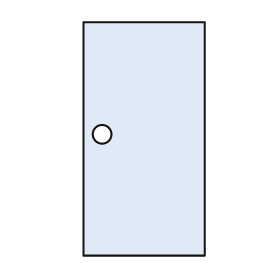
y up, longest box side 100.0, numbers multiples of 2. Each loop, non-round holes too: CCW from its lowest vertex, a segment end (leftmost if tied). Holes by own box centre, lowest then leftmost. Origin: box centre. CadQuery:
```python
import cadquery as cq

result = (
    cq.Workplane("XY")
    .moveTo(-26.0, -50.0)
    .lineTo(26.0, -50.0)
    .lineTo(26.0, 50.0)
    .lineTo(-26.0, 50.0)
    .close()
    .moveTo(-18.0, 2.0)
    .circle(4.0)
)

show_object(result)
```